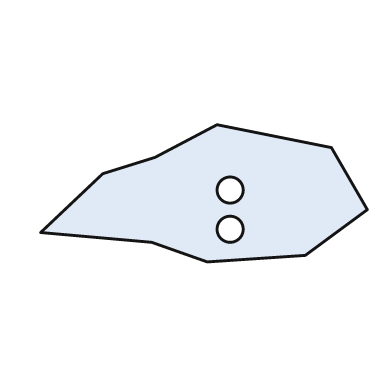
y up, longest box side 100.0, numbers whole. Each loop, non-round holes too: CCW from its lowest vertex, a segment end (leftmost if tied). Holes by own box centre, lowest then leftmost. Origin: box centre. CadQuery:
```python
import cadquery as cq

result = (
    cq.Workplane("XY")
    .moveTo(1.0, -21.0)
    .lineTo(31.0, -19.0)
    .lineTo(50.0, -5.0)
    .lineTo(39.0, 14.0)
    .lineTo(4.0, 21.0)
    .lineTo(-15.0, 11.0)
    .lineTo(-31.0, 6.0)
    .lineTo(-50.0, -12.0)
    .lineTo(-16.0, -15.0)
    .close()
    .moveTo(8.0, -11.0)
    .circle(4.0)
    .moveTo(8.0, 1.0)
    .circle(4.0)
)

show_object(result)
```